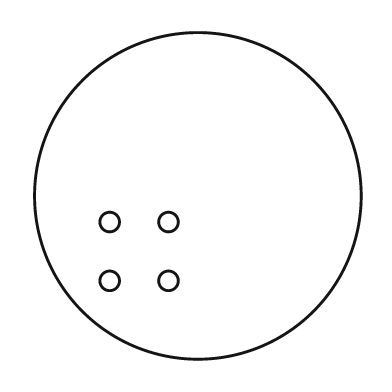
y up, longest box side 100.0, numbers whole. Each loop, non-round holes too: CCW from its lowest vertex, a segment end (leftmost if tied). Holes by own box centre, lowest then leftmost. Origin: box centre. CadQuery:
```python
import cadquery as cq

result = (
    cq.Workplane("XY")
    .moveTo(0.0, 0.0)
    .circle(50.0)
    .moveTo(-27.0, -26.0)
    .circle(3.0)
    .moveTo(-9.0, -26.0)
    .circle(3.0)
    .moveTo(-27.0, -8.0)
    .circle(3.0)
    .moveTo(-9.0, -8.0)
    .circle(3.0)
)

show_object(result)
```